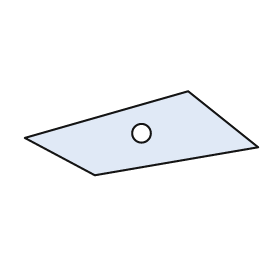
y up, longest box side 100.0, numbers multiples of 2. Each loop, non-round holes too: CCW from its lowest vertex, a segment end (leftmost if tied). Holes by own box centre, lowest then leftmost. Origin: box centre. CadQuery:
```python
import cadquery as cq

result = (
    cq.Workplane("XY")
    .moveTo(-20.0, -18.0)
    .lineTo(50.0, -6.0)
    .lineTo(20.0, 18.0)
    .lineTo(-50.0, -2.0)
    .close()
    .moveTo(0.0, 0.0)
    .circle(4.0)
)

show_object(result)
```